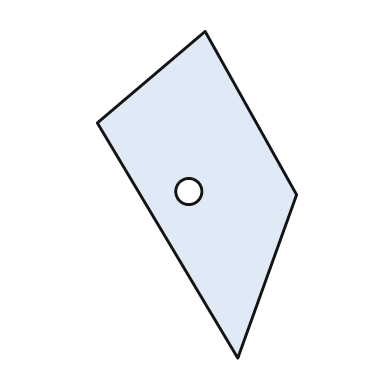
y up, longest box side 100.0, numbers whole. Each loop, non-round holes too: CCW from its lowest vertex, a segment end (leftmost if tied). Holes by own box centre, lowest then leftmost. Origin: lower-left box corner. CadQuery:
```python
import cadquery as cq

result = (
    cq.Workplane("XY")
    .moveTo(43.0, 0.0)
    .lineTo(61.0, 50.0)
    .lineTo(33.0, 100.0)
    .lineTo(0.0, 72.0)
    .close()
    .moveTo(28.0, 51.0)
    .circle(4.0)
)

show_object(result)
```